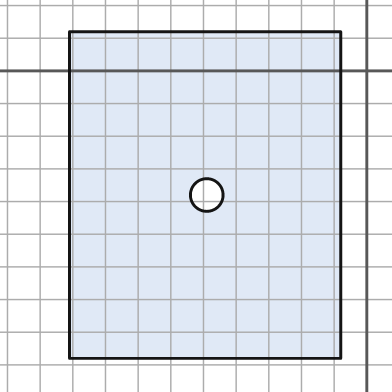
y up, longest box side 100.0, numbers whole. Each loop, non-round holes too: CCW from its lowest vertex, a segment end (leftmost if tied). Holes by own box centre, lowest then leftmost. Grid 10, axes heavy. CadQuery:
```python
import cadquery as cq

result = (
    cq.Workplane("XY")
    .moveTo(-91.0, -88.0)
    .lineTo(-8.0, -88.0)
    .lineTo(-8.0, 12.0)
    .lineTo(-91.0, 12.0)
    .close()
    .moveTo(-49.0, -38.0)
    .circle(5.0)
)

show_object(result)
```